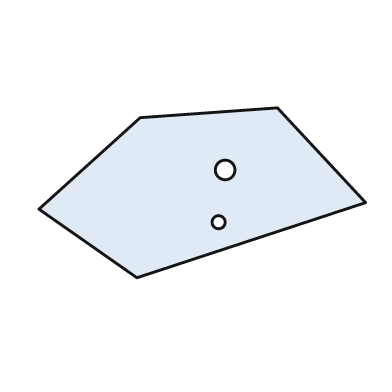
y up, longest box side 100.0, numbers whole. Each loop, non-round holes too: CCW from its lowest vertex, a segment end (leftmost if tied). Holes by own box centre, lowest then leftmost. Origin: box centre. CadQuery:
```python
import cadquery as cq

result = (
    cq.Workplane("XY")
    .moveTo(-20.0, -26.0)
    .lineTo(50.0, -3.0)
    .lineTo(23.0, 26.0)
    .lineTo(-19.0, 23.0)
    .lineTo(-50.0, -5.0)
    .close()
    .moveTo(5.0, -9.0)
    .circle(2.0)
    .moveTo(7.0, 7.0)
    .circle(3.0)
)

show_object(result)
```